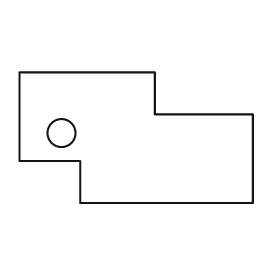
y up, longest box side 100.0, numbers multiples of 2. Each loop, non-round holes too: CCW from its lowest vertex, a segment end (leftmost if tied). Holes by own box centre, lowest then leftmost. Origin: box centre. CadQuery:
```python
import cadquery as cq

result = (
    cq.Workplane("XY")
    .moveTo(-24.0, -28.0)
    .lineTo(50.0, -28.0)
    .lineTo(50.0, 10.0)
    .lineTo(8.0, 10.0)
    .lineTo(8.0, 28.0)
    .lineTo(-50.0, 28.0)
    .lineTo(-50.0, -10.0)
    .lineTo(-24.0, -10.0)
    .close()
    .moveTo(-32.0, 2.0)
    .circle(6.0)
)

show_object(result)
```